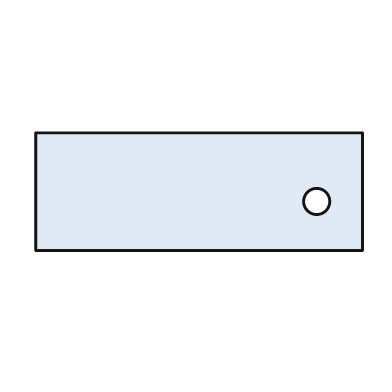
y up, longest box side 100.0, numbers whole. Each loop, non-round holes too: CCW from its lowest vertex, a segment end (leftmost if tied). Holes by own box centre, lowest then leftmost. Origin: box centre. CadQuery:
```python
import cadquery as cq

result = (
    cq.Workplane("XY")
    .moveTo(-50.0, -18.0)
    .lineTo(50.0, -18.0)
    .lineTo(50.0, 18.0)
    .lineTo(-50.0, 18.0)
    .close()
    .moveTo(36.0, -3.0)
    .circle(4.0)
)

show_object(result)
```